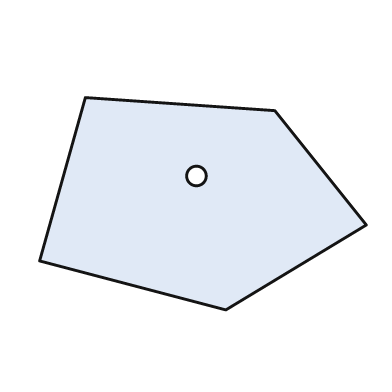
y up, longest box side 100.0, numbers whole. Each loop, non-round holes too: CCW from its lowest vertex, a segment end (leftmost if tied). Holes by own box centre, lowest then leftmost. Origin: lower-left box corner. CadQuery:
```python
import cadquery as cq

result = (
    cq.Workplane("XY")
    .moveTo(57.0, 0.0)
    .lineTo(100.0, 26.0)
    .lineTo(72.0, 61.0)
    .lineTo(14.0, 65.0)
    .lineTo(0.0, 15.0)
    .close()
    .moveTo(48.0, 41.0)
    .circle(3.0)
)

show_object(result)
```